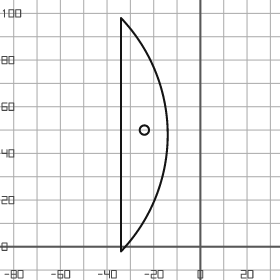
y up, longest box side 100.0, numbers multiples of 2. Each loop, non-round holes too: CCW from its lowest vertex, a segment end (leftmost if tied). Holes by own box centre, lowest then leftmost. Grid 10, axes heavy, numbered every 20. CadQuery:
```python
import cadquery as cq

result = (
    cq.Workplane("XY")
    .moveTo(-34.0, -2.0)
    .threePointArc((-14.0, 48.0), (-34.0, 98.0))
    .close()
    .moveTo(-24.0, 50.0)
    .circle(2.0)
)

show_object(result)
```